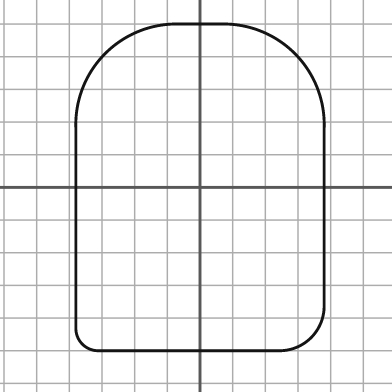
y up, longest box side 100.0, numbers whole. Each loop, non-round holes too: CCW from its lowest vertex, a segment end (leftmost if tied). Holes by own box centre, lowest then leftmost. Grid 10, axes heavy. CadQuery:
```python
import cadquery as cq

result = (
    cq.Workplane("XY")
    .moveTo(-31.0, -50.0)
    .lineTo(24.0, -50.0)
    .threePointArc((34.0, -46.0), (38.0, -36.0))
    .lineTo(38.0, 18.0)
    .threePointArc((29.0, 41.0), (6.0, 50.0))
    .lineTo(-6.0, 50.0)
    .threePointArc((-29.0, 41.0), (-38.0, 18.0))
    .lineTo(-38.0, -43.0)
    .threePointArc((-36.0, -48.0), (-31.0, -50.0))
    .close()
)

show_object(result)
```